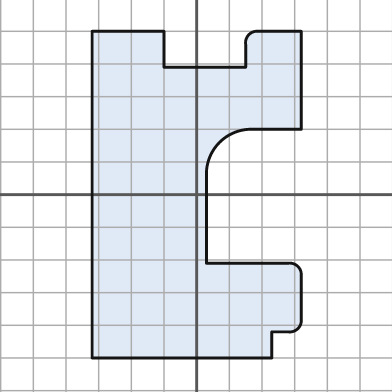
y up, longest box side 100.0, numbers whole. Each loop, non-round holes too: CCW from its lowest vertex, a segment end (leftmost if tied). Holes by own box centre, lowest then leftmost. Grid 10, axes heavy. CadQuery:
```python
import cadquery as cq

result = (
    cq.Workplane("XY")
    .moveTo(-32.0, -50.0)
    .lineTo(23.0, -50.0)
    .lineTo(23.0, -42.0)
    .lineTo(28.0, -42.0)
    .threePointArc((31.0, -41.0), (32.0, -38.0))
    .lineTo(32.0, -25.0)
    .threePointArc((31.0, -22.0), (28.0, -21.0))
    .lineTo(3.0, -21.0)
    .lineTo(3.0, 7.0)
    .threePointArc((7.0, 16.0), (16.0, 20.0))
    .lineTo(32.0, 20.0)
    .lineTo(32.0, 50.0)
    .lineTo(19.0, 50.0)
    .threePointArc((16.0, 49.0), (15.0, 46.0))
    .lineTo(15.0, 39.0)
    .lineTo(-10.0, 39.0)
    .lineTo(-10.0, 50.0)
    .lineTo(-32.0, 50.0)
    .close()
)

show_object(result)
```